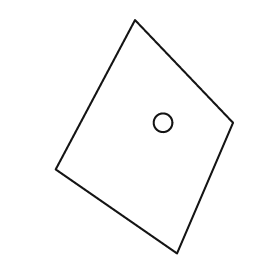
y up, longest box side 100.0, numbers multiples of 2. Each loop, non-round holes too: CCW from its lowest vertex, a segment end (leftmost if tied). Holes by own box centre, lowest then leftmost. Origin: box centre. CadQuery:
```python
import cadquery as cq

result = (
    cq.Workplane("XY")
    .moveTo(14.0, -50.0)
    .lineTo(38.0, 6.0)
    .lineTo(-4.0, 50.0)
    .lineTo(-38.0, -14.0)
    .close()
    .moveTo(8.0, 6.0)
    .circle(4.0)
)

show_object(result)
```